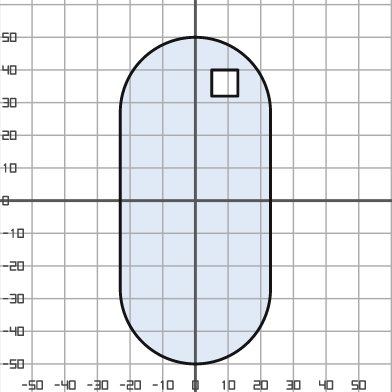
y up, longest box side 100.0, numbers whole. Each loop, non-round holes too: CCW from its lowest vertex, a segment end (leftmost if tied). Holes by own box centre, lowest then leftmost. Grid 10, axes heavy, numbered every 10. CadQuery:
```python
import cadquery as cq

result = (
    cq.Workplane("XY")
    .moveTo(-23.0, -27.0)
    .threePointArc((0.0, -50.0), (23.0, -27.0))
    .lineTo(23.0, 27.0)
    .threePointArc((0.0, 50.0), (-23.0, 27.0))
    .close()
    .moveTo(5.0, 32.0)
    .lineTo(13.0, 32.0)
    .lineTo(13.0, 40.0)
    .lineTo(5.0, 40.0)
    .close()
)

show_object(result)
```